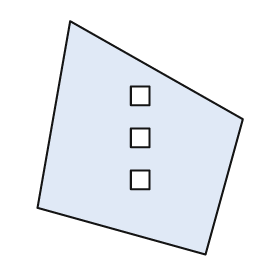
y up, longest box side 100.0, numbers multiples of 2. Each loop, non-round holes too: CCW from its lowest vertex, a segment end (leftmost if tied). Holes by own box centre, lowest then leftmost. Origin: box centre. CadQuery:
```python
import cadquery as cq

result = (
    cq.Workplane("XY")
    .moveTo(28.0, -50.0)
    .lineTo(44.0, 8.0)
    .lineTo(-30.0, 50.0)
    .lineTo(-44.0, -30.0)
    .close()
    .moveTo(-4.0, -22.0)
    .lineTo(4.0, -22.0)
    .lineTo(4.0, -14.0)
    .lineTo(-4.0, -14.0)
    .close()
    .moveTo(-4.0, -4.0)
    .lineTo(4.0, -4.0)
    .lineTo(4.0, 4.0)
    .lineTo(-4.0, 4.0)
    .close()
    .moveTo(-4.0, 14.0)
    .lineTo(4.0, 14.0)
    .lineTo(4.0, 22.0)
    .lineTo(-4.0, 22.0)
    .close()
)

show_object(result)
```